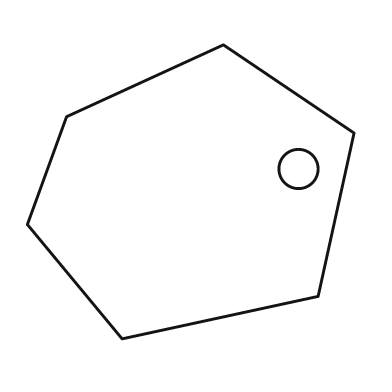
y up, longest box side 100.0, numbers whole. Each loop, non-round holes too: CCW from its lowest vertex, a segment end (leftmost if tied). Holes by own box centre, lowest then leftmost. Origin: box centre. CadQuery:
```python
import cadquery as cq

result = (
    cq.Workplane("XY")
    .moveTo(-21.0, -45.0)
    .lineTo(39.0, -32.0)
    .lineTo(50.0, 18.0)
    .lineTo(10.0, 45.0)
    .lineTo(-38.0, 23.0)
    .lineTo(-50.0, -10.0)
    .close()
    .moveTo(33.0, 7.0)
    .circle(6.0)
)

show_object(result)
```